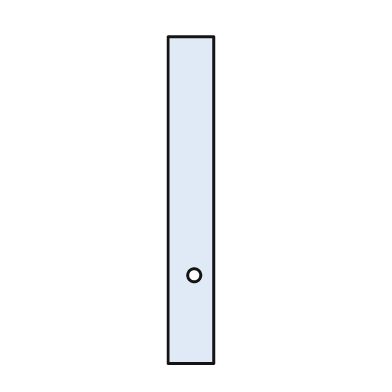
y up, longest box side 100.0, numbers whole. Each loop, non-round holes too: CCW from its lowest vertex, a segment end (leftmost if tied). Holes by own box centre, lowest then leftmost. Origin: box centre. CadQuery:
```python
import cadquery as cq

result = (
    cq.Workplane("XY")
    .moveTo(-7.0, -50.0)
    .lineTo(7.0, -50.0)
    .lineTo(7.0, 50.0)
    .lineTo(-7.0, 50.0)
    .close()
    .moveTo(1.0, -23.0)
    .circle(2.0)
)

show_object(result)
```